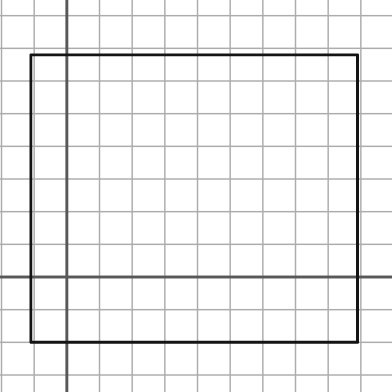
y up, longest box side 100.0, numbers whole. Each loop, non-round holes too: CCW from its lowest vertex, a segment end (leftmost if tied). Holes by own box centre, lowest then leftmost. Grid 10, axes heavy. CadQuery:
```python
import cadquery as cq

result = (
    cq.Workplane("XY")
    .moveTo(-11.0, -20.0)
    .lineTo(89.0, -20.0)
    .lineTo(89.0, 68.0)
    .lineTo(-11.0, 68.0)
    .close()
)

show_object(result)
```